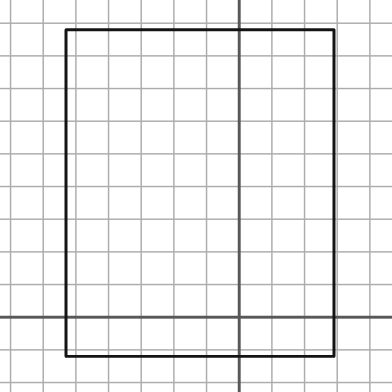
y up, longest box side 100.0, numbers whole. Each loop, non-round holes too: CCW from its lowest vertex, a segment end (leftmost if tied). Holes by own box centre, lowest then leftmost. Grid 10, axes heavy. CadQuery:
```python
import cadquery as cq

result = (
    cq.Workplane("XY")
    .moveTo(-53.0, -12.0)
    .lineTo(29.0, -12.0)
    .lineTo(29.0, 88.0)
    .lineTo(-53.0, 88.0)
    .close()
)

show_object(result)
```